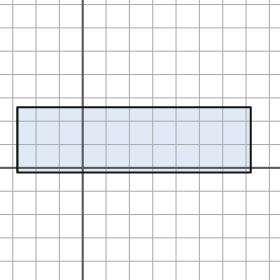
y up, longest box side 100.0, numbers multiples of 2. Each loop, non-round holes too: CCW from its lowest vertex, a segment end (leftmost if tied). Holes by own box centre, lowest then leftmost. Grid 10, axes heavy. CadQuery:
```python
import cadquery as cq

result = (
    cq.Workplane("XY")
    .moveTo(-28.0, -2.0)
    .lineTo(72.0, -2.0)
    .lineTo(72.0, 26.0)
    .lineTo(-28.0, 26.0)
    .close()
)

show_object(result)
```